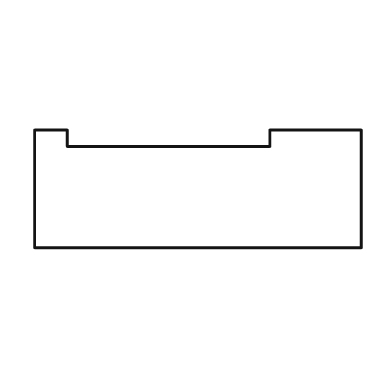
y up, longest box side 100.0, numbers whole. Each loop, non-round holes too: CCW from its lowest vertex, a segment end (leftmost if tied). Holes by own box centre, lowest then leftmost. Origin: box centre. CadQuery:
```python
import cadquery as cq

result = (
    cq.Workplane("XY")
    .moveTo(-50.0, -18.0)
    .lineTo(50.0, -18.0)
    .lineTo(50.0, 18.0)
    .lineTo(22.0, 18.0)
    .lineTo(22.0, 13.0)
    .lineTo(-40.0, 13.0)
    .lineTo(-40.0, 18.0)
    .lineTo(-50.0, 18.0)
    .close()
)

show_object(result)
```